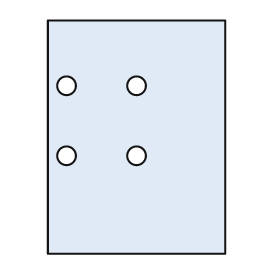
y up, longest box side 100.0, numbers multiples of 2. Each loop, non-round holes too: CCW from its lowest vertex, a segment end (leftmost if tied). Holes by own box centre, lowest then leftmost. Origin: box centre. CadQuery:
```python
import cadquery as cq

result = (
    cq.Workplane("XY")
    .moveTo(-38.0, -50.0)
    .lineTo(38.0, -50.0)
    .lineTo(38.0, 50.0)
    .lineTo(-38.0, 50.0)
    .close()
    .moveTo(-30.0, -8.0)
    .circle(4.0)
    .moveTo(0.0, -8.0)
    .circle(4.0)
    .moveTo(-30.0, 22.0)
    .circle(4.0)
    .moveTo(0.0, 22.0)
    .circle(4.0)
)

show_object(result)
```